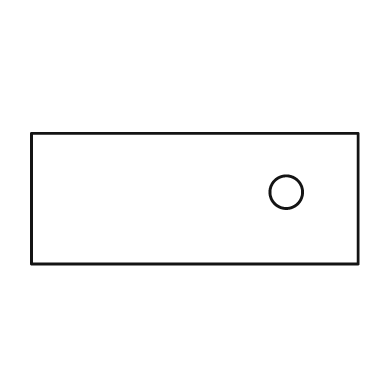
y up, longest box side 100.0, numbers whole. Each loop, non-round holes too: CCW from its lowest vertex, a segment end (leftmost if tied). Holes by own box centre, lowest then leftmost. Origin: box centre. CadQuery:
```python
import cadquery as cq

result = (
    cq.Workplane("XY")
    .moveTo(-50.0, -20.0)
    .lineTo(50.0, -20.0)
    .lineTo(50.0, 20.0)
    .lineTo(-50.0, 20.0)
    .close()
    .moveTo(28.0, 2.0)
    .circle(5.0)
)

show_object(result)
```